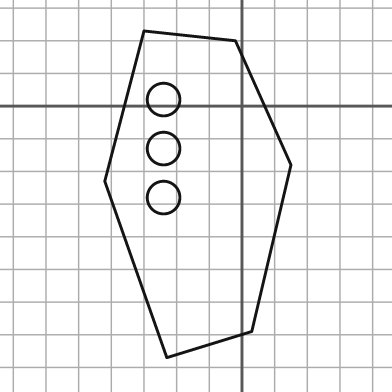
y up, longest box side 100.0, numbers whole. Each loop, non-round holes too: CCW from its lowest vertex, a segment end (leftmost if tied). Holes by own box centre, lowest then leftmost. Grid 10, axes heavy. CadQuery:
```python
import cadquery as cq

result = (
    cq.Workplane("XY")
    .moveTo(-23.0, -77.0)
    .lineTo(3.0, -69.0)
    .lineTo(15.0, -18.0)
    .lineTo(-2.0, 20.0)
    .lineTo(-30.0, 23.0)
    .lineTo(-42.0, -23.0)
    .close()
    .moveTo(-24.0, -28.0)
    .circle(5.0)
    .moveTo(-24.0, -13.0)
    .circle(5.0)
    .moveTo(-24.0, 2.0)
    .circle(5.0)
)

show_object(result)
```